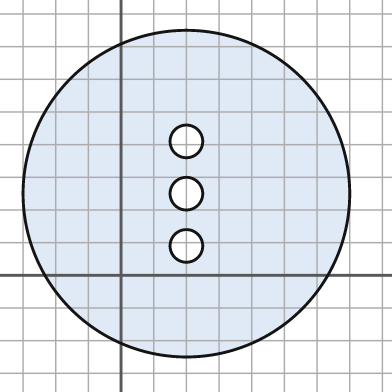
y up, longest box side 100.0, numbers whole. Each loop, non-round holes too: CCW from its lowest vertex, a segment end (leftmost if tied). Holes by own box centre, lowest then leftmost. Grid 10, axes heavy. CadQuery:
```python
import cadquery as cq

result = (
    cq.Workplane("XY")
    .moveTo(20.0, 25.0)
    .circle(50.0)
    .moveTo(20.0, 9.0)
    .circle(5.0)
    .moveTo(20.0, 25.0)
    .circle(5.0)
    .moveTo(20.0, 41.0)
    .circle(5.0)
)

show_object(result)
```